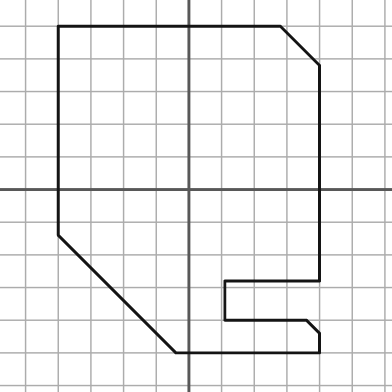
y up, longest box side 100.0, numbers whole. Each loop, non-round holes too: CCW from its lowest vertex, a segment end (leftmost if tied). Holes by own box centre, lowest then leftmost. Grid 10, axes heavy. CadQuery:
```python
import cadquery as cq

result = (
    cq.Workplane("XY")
    .moveTo(-4.0, -50.0)
    .lineTo(40.0, -50.0)
    .lineTo(40.0, -44.0)
    .lineTo(36.0, -40.0)
    .lineTo(11.0, -40.0)
    .lineTo(11.0, -28.0)
    .lineTo(40.0, -28.0)
    .lineTo(40.0, 38.0)
    .lineTo(28.0, 50.0)
    .lineTo(-40.0, 50.0)
    .lineTo(-40.0, -14.0)
    .close()
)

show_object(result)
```